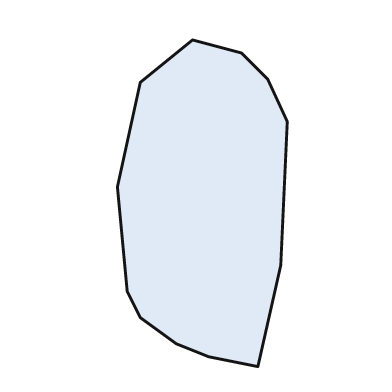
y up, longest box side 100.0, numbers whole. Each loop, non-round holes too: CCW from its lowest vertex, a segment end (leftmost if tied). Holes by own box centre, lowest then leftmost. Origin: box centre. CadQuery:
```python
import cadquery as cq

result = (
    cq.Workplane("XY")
    .moveTo(17.0, -50.0)
    .lineTo(24.0, -19.0)
    .lineTo(26.0, 25.0)
    .lineTo(20.0, 38.0)
    .lineTo(12.0, 46.0)
    .lineTo(-3.0, 50.0)
    .lineTo(-19.0, 37.0)
    .lineTo(-26.0, 5.0)
    .lineTo(-23.0, -27.0)
    .lineTo(-19.0, -35.0)
    .lineTo(-8.0, -43.0)
    .lineTo(2.0, -47.0)
    .close()
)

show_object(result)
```